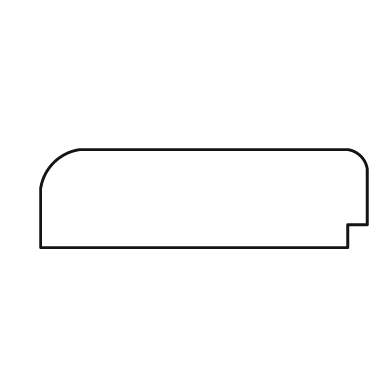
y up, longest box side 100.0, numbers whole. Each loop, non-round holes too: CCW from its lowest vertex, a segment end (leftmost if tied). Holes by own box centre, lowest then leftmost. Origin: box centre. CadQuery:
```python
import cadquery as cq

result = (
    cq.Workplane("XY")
    .moveTo(-50.0, -15.0)
    .lineTo(44.0, -15.0)
    .lineTo(44.0, -8.0)
    .lineTo(50.0, -8.0)
    .lineTo(50.0, 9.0)
    .threePointArc((48.0, 13.0), (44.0, 15.0))
    .lineTo(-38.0, 15.0)
    .threePointArc((-46.0, 11.0), (-50.0, 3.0))
    .close()
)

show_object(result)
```